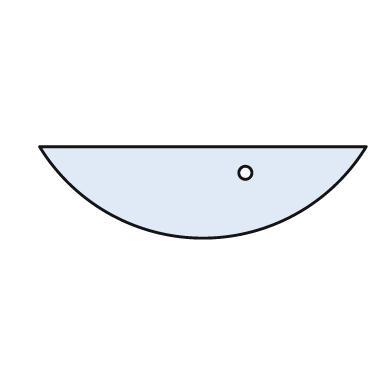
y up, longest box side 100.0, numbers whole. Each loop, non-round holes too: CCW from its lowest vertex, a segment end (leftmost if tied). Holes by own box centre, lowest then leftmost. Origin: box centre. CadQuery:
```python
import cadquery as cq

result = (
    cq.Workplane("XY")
    .moveTo(-50.0, 14.0)
    .threePointArc((0.0, -14.0), (50.0, 14.0))
    .close()
    .moveTo(13.0, 6.0)
    .circle(2.0)
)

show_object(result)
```